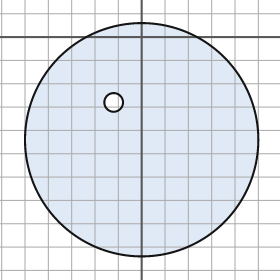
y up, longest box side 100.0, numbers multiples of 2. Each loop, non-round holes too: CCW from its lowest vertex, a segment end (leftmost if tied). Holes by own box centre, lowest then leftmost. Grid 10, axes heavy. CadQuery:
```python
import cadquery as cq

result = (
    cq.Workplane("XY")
    .moveTo(0.0, -44.0)
    .circle(50.0)
    .moveTo(-12.0, -28.0)
    .circle(4.0)
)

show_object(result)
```